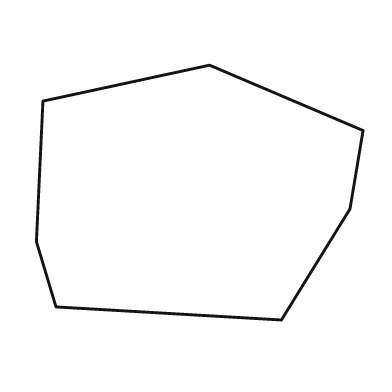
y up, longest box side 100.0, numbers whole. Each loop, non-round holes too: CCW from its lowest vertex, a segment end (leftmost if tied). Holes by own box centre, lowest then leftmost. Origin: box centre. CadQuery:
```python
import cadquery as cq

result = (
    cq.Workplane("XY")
    .moveTo(25.0, -39.0)
    .lineTo(46.0, -5.0)
    .lineTo(50.0, 19.0)
    .lineTo(3.0, 39.0)
    .lineTo(-48.0, 28.0)
    .lineTo(-50.0, -15.0)
    .lineTo(-44.0, -35.0)
    .close()
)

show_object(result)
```